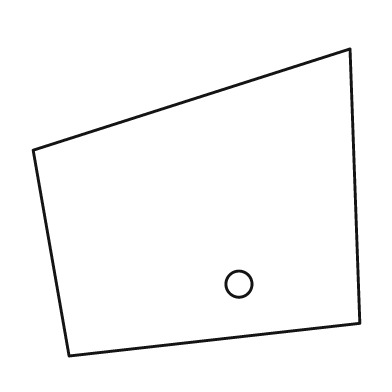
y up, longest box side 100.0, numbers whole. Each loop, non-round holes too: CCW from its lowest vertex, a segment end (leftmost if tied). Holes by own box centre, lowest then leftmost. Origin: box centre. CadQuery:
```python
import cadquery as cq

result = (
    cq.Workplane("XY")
    .moveTo(-39.0, -47.0)
    .lineTo(50.0, -37.0)
    .lineTo(47.0, 47.0)
    .lineTo(-50.0, 16.0)
    .close()
    .moveTo(13.0, -25.0)
    .circle(4.0)
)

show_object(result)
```